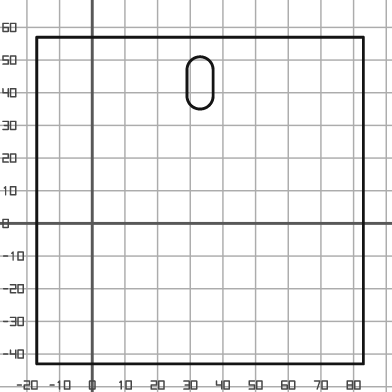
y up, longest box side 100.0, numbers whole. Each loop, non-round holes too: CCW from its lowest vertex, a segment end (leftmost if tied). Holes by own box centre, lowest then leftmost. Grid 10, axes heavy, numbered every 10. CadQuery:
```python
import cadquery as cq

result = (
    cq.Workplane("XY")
    .moveTo(-17.0, -43.0)
    .lineTo(83.0, -43.0)
    .lineTo(83.0, 57.0)
    .lineTo(-17.0, 57.0)
    .close()
    .moveTo(29.0, 39.0)
    .threePointArc((33.0, 35.0), (37.0, 39.0))
    .lineTo(37.0, 47.0)
    .threePointArc((33.0, 51.0), (29.0, 47.0))
    .close()
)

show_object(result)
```